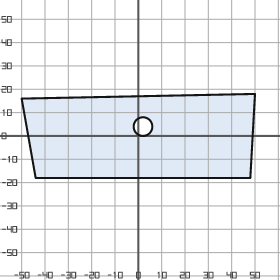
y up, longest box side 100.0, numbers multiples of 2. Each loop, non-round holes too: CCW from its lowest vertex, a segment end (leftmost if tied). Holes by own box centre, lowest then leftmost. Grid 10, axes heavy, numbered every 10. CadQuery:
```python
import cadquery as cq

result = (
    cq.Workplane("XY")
    .moveTo(-44.0, -18.0)
    .lineTo(48.0, -18.0)
    .lineTo(50.0, 18.0)
    .lineTo(-50.0, 16.0)
    .close()
    .moveTo(2.0, 4.0)
    .circle(4.0)
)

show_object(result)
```